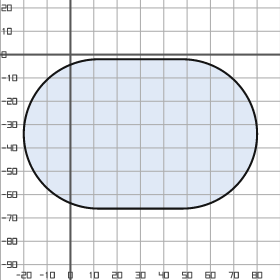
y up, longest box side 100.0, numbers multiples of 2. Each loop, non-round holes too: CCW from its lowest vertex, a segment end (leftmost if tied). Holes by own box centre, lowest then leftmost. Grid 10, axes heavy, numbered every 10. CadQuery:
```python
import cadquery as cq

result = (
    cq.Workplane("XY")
    .moveTo(12.0, -66.0)
    .lineTo(48.0, -66.0)
    .threePointArc((80.0, -34.0), (48.0, -2.0))
    .lineTo(12.0, -2.0)
    .threePointArc((-20.0, -34.0), (12.0, -66.0))
    .close()
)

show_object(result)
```